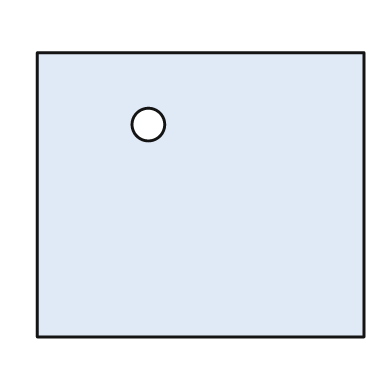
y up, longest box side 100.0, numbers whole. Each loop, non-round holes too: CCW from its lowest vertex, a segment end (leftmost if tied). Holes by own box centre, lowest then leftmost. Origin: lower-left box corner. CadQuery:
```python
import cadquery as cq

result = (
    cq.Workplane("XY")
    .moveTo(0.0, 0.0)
    .lineTo(100.0, 0.0)
    .lineTo(100.0, 87.0)
    .lineTo(0.0, 87.0)
    .close()
    .moveTo(34.0, 65.0)
    .circle(5.0)
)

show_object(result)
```